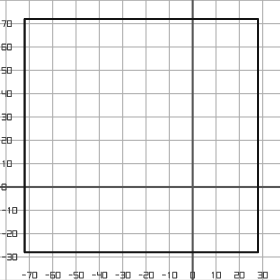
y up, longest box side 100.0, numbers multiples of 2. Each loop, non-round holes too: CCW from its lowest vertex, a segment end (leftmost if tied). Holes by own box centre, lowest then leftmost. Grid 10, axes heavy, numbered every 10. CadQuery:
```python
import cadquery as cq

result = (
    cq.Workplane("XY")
    .moveTo(-72.0, -28.0)
    .lineTo(28.0, -28.0)
    .lineTo(28.0, 72.0)
    .lineTo(-72.0, 72.0)
    .close()
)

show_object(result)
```